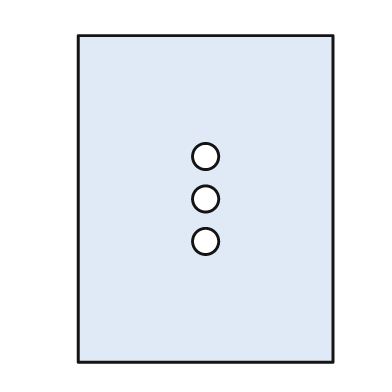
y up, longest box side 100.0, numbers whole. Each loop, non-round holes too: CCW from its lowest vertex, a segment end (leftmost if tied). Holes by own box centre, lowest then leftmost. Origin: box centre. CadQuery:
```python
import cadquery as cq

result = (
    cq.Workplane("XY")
    .moveTo(-39.0, -50.0)
    .lineTo(39.0, -50.0)
    .lineTo(39.0, 50.0)
    .lineTo(-39.0, 50.0)
    .close()
    .moveTo(0.0, -13.0)
    .circle(4.0)
    .moveTo(0.0, 0.0)
    .circle(4.0)
    .moveTo(0.0, 13.0)
    .circle(4.0)
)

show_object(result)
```